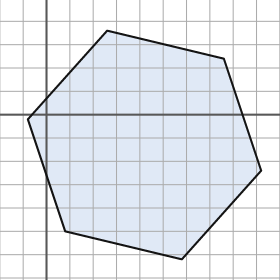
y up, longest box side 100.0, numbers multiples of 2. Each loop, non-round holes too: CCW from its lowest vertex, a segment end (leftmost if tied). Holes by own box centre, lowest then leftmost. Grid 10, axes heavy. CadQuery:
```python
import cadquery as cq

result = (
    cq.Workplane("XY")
    .moveTo(58.0, -62.0)
    .lineTo(92.0, -24.0)
    .lineTo(76.0, 24.0)
    .lineTo(26.0, 36.0)
    .lineTo(-8.0, -2.0)
    .lineTo(8.0, -50.0)
    .close()
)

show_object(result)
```